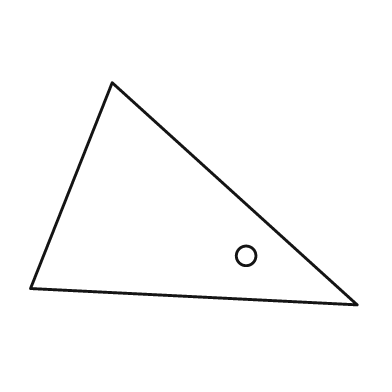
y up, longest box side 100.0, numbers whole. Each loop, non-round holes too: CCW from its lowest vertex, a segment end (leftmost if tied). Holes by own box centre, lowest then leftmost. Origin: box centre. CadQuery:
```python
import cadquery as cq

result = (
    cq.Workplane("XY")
    .moveTo(50.0, -34.0)
    .lineTo(-25.0, 34.0)
    .lineTo(-50.0, -29.0)
    .close()
    .moveTo(16.0, -19.0)
    .circle(3.0)
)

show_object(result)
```